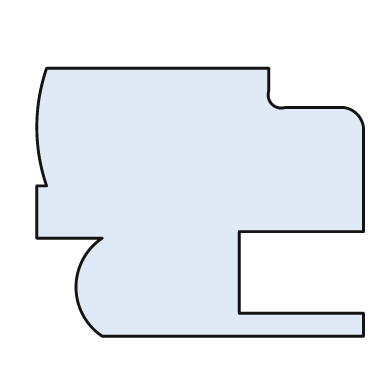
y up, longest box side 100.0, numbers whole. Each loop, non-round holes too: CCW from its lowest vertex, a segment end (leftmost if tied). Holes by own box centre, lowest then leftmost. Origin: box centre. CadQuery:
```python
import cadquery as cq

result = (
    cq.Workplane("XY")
    .moveTo(-30.0, -41.0)
    .lineTo(50.0, -41.0)
    .lineTo(50.0, -34.0)
    .lineTo(12.0, -34.0)
    .lineTo(12.0, -9.0)
    .lineTo(50.0, -9.0)
    .lineTo(50.0, 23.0)
    .threePointArc((48.0, 27.0), (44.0, 29.0))
    .lineTo(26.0, 29.0)
    .threePointArc((22.0, 30.0), (21.0, 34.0))
    .lineTo(21.0, 41.0)
    .lineTo(-47.0, 41.0)
    .threePointArc((-50.0, 23.0), (-47.0, 5.0))
    .lineTo(-50.0, 5.0)
    .lineTo(-50.0, -11.0)
    .lineTo(-30.0, -11.0)
    .threePointArc((-38.0, -26.0), (-30.0, -41.0))
    .close()
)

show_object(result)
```